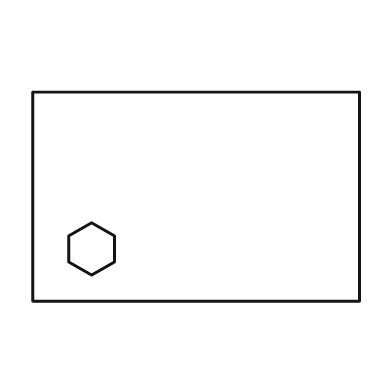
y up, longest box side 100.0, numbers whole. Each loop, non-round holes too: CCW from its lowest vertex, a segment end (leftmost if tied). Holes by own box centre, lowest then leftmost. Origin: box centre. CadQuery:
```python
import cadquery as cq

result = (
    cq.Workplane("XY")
    .moveTo(-50.0, -32.0)
    .lineTo(50.0, -32.0)
    .lineTo(50.0, 32.0)
    .lineTo(-50.0, 32.0)
    .close()
    .moveTo(-32.0, -24.0)
    .lineTo(-25.0, -20.0)
    .lineTo(-25.0, -12.0)
    .lineTo(-32.0, -8.0)
    .lineTo(-39.0, -12.0)
    .lineTo(-39.0, -20.0)
    .close()
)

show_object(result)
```